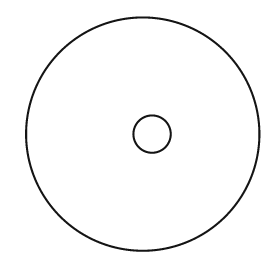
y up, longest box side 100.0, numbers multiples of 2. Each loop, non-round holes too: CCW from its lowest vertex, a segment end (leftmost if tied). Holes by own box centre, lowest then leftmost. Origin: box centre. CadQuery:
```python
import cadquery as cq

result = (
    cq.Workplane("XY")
    .moveTo(0.0, 0.0)
    .circle(50.0)
    .moveTo(4.0, 0.0)
    .circle(8.0)
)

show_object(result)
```